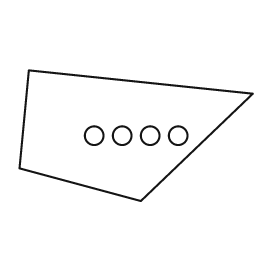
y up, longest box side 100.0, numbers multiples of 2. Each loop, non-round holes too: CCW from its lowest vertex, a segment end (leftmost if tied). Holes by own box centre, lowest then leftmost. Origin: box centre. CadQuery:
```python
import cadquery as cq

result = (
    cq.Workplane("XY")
    .moveTo(2.0, -28.0)
    .lineTo(50.0, 18.0)
    .lineTo(-46.0, 28.0)
    .lineTo(-50.0, -14.0)
    .close()
    .moveTo(-18.0, 0.0)
    .circle(4.0)
    .moveTo(-6.0, 0.0)
    .circle(4.0)
    .moveTo(6.0, 0.0)
    .circle(4.0)
    .moveTo(18.0, 0.0)
    .circle(4.0)
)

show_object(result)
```